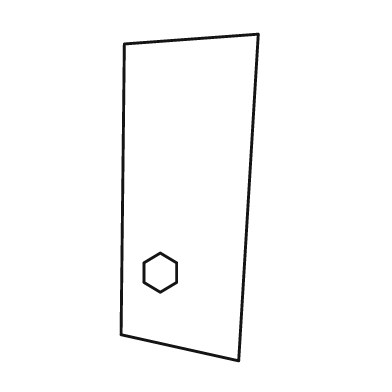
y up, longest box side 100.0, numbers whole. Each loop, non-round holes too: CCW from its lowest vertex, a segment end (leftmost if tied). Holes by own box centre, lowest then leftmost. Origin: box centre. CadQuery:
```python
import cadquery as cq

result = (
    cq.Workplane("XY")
    .moveTo(15.0, -50.0)
    .lineTo(21.0, 50.0)
    .lineTo(-20.0, 47.0)
    .lineTo(-21.0, -42.0)
    .close()
    .moveTo(-9.0, -29.0)
    .lineTo(-4.0, -26.0)
    .lineTo(-4.0, -20.0)
    .lineTo(-9.0, -17.0)
    .lineTo(-14.0, -20.0)
    .lineTo(-14.0, -26.0)
    .close()
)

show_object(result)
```